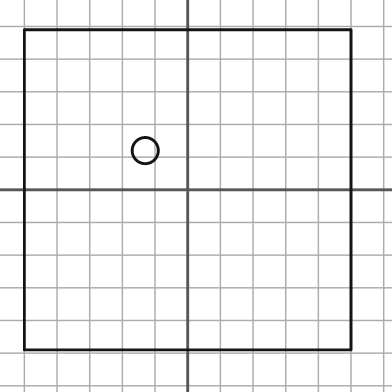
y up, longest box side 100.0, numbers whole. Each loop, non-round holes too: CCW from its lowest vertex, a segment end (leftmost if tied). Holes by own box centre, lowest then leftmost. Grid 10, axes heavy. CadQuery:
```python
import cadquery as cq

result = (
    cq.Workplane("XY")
    .moveTo(-50.0, -49.0)
    .lineTo(50.0, -49.0)
    .lineTo(50.0, 49.0)
    .lineTo(-50.0, 49.0)
    .close()
    .moveTo(-13.0, 12.0)
    .circle(4.0)
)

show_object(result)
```